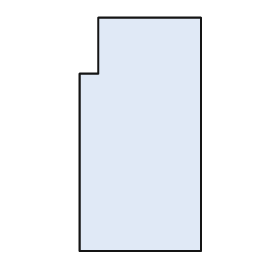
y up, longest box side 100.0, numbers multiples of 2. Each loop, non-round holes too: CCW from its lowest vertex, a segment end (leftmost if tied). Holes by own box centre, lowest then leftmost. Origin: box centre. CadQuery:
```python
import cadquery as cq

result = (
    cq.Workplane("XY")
    .moveTo(-26.0, -50.0)
    .lineTo(26.0, -50.0)
    .lineTo(26.0, 50.0)
    .lineTo(-18.0, 50.0)
    .lineTo(-18.0, 26.0)
    .lineTo(-26.0, 26.0)
    .close()
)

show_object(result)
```